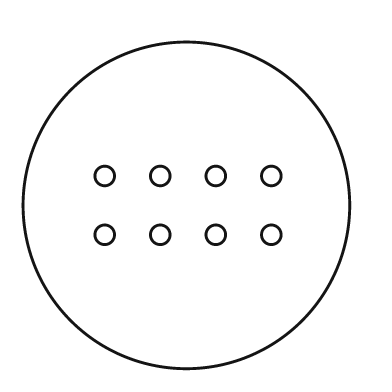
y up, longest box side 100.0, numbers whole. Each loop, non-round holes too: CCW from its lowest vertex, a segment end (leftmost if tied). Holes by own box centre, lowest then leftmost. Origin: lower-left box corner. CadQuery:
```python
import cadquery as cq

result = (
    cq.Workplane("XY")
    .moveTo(50.0, 50.0)
    .circle(50.0)
    .moveTo(25.0, 41.0)
    .circle(3.0)
    .moveTo(42.0, 41.0)
    .circle(3.0)
    .moveTo(59.0, 41.0)
    .circle(3.0)
    .moveTo(76.0, 41.0)
    .circle(3.0)
    .moveTo(25.0, 59.0)
    .circle(3.0)
    .moveTo(42.0, 59.0)
    .circle(3.0)
    .moveTo(59.0, 59.0)
    .circle(3.0)
    .moveTo(76.0, 59.0)
    .circle(3.0)
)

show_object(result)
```